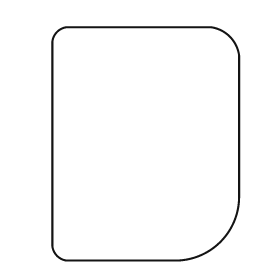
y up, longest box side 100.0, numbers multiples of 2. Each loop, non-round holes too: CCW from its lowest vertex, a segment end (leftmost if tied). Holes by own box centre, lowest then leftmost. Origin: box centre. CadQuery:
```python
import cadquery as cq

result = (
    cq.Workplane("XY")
    .moveTo(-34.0, -50.0)
    .lineTo(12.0, -50.0)
    .threePointArc((32.0, -42.0), (40.0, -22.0))
    .lineTo(40.0, 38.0)
    .threePointArc((36.0, 46.0), (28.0, 50.0))
    .lineTo(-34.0, 50.0)
    .threePointArc((-38.0, 48.0), (-40.0, 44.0))
    .lineTo(-40.0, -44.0)
    .threePointArc((-38.0, -48.0), (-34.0, -50.0))
    .close()
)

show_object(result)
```